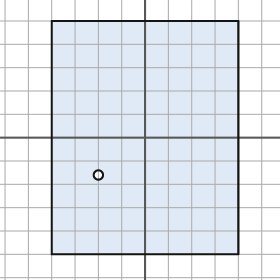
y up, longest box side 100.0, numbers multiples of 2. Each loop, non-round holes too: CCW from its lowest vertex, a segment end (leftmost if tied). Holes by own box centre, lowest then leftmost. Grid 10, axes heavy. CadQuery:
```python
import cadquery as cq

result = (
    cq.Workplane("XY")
    .moveTo(-40.0, -50.0)
    .lineTo(40.0, -50.0)
    .lineTo(40.0, 50.0)
    .lineTo(-40.0, 50.0)
    .close()
    .moveTo(-20.0, -16.0)
    .circle(2.0)
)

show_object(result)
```